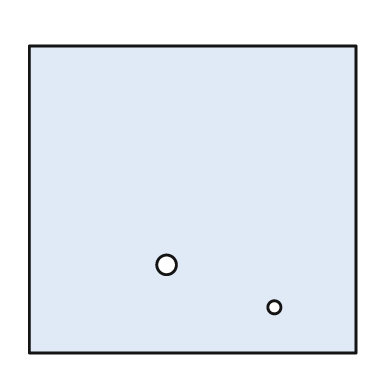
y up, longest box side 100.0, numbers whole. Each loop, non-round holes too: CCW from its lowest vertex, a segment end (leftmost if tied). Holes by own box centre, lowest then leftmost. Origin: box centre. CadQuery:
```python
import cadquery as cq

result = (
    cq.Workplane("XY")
    .moveTo(-50.0, -47.0)
    .lineTo(50.0, -47.0)
    .lineTo(50.0, 47.0)
    .lineTo(-50.0, 47.0)
    .close()
    .moveTo(25.0, -33.0)
    .circle(2.0)
    .moveTo(-8.0, -20.0)
    .circle(3.0)
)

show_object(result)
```